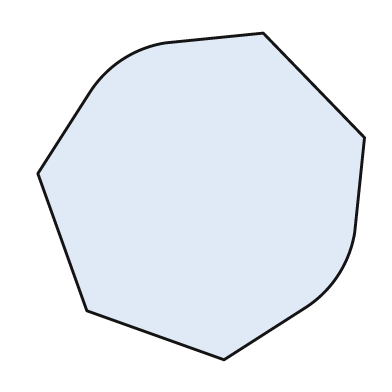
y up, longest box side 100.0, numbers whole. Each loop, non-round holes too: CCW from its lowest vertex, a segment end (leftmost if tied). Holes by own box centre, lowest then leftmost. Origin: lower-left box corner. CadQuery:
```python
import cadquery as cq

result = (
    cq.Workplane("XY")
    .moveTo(57.0, 0.0)
    .lineTo(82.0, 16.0)
    .threePointArc((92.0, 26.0), (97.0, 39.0))
    .lineTo(100.0, 68.0)
    .lineTo(69.0, 100.0)
    .lineTo(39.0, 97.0)
    .threePointArc((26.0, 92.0), (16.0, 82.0))
    .lineTo(0.0, 57.0)
    .lineTo(15.0, 15.0)
    .close()
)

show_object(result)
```